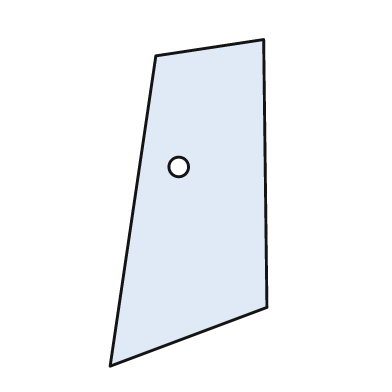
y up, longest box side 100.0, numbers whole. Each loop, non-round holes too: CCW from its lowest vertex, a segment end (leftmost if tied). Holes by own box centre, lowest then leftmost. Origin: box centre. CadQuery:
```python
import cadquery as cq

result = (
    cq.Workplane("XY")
    .moveTo(-24.0, -50.0)
    .lineTo(24.0, -32.0)
    .lineTo(23.0, 50.0)
    .lineTo(-10.0, 45.0)
    .close()
    .moveTo(-3.0, 11.0)
    .circle(3.0)
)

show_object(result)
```